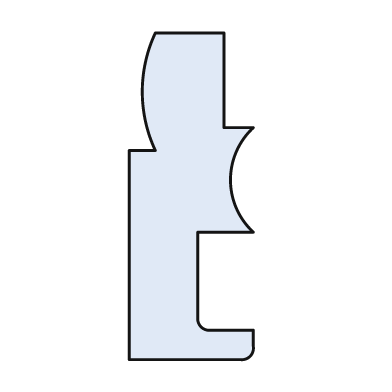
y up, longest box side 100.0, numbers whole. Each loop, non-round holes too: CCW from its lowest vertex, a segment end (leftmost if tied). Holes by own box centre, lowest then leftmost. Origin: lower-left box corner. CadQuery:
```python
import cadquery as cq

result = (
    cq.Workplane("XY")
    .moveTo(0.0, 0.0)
    .lineTo(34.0, 0.0)
    .threePointArc((37.0, 1.0), (38.0, 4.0))
    .lineTo(38.0, 9.0)
    .lineTo(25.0, 9.0)
    .threePointArc((22.0, 10.0), (21.0, 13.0))
    .lineTo(21.0, 39.0)
    .lineTo(38.0, 39.0)
    .threePointArc((31.0, 55.0), (38.0, 71.0))
    .lineTo(29.0, 71.0)
    .lineTo(29.0, 100.0)
    .lineTo(8.0, 100.0)
    .threePointArc((4.0, 82.0), (8.0, 64.0))
    .lineTo(0.0, 64.0)
    .close()
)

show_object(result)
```